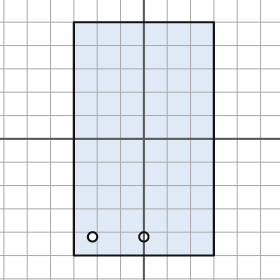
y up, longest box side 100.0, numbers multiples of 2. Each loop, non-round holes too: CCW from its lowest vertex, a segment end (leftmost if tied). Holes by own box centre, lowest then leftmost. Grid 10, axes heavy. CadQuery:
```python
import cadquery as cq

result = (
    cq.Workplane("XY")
    .moveTo(-30.0, -50.0)
    .lineTo(30.0, -50.0)
    .lineTo(30.0, 50.0)
    .lineTo(-30.0, 50.0)
    .close()
    .moveTo(-22.0, -42.0)
    .circle(2.0)
    .moveTo(0.0, -42.0)
    .circle(2.0)
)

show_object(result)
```